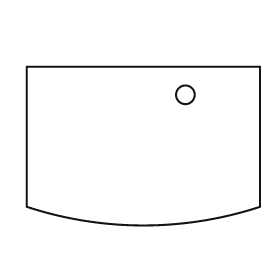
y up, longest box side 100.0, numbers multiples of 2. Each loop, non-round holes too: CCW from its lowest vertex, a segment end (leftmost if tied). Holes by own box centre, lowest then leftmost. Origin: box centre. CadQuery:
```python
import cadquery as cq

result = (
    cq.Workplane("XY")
    .moveTo(-50.0, -26.0)
    .threePointArc((0.0, -34.0), (50.0, -26.0))
    .lineTo(50.0, 34.0)
    .lineTo(-50.0, 34.0)
    .close()
    .moveTo(18.0, 22.0)
    .circle(4.0)
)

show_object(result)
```